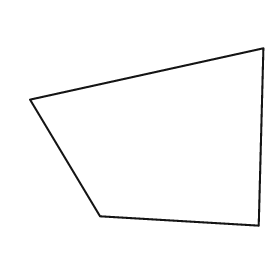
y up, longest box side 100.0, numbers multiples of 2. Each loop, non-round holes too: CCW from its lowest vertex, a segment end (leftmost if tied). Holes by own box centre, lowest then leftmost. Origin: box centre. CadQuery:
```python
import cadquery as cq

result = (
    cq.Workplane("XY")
    .moveTo(48.0, -38.0)
    .lineTo(50.0, 38.0)
    .lineTo(-50.0, 16.0)
    .lineTo(-20.0, -34.0)
    .close()
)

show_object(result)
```